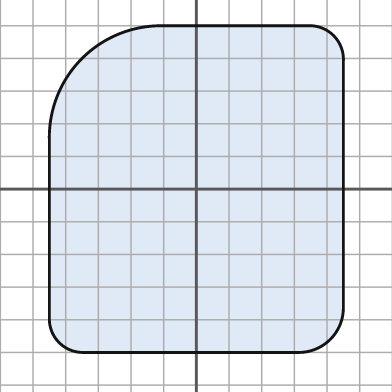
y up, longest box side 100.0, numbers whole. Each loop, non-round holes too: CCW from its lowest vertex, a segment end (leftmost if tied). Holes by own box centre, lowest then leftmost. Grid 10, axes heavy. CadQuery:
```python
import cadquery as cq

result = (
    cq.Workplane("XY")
    .moveTo(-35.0, -50.0)
    .lineTo(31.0, -50.0)
    .threePointArc((41.0, -46.0), (45.0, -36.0))
    .lineTo(45.0, 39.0)
    .threePointArc((42.0, 47.0), (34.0, 50.0))
    .lineTo(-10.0, 50.0)
    .threePointArc((-35.0, 40.0), (-45.0, 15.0))
    .lineTo(-45.0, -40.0)
    .threePointArc((-42.0, -47.0), (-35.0, -50.0))
    .close()
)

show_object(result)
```